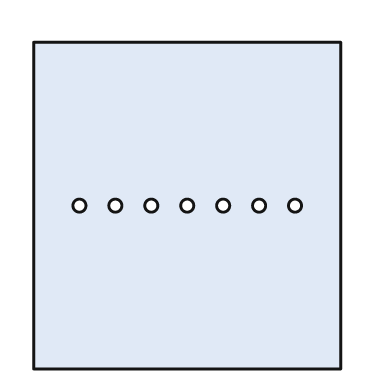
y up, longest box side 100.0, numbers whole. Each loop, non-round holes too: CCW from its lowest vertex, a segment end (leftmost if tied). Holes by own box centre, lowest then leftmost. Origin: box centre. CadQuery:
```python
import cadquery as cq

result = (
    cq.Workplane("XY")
    .moveTo(-47.0, -50.0)
    .lineTo(47.0, -50.0)
    .lineTo(47.0, 50.0)
    .lineTo(-47.0, 50.0)
    .close()
    .moveTo(-33.0, 0.0)
    .circle(2.0)
    .moveTo(-22.0, 0.0)
    .circle(2.0)
    .moveTo(-11.0, 0.0)
    .circle(2.0)
    .moveTo(0.0, 0.0)
    .circle(2.0)
    .moveTo(11.0, 0.0)
    .circle(2.0)
    .moveTo(22.0, 0.0)
    .circle(2.0)
    .moveTo(33.0, 0.0)
    .circle(2.0)
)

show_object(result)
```